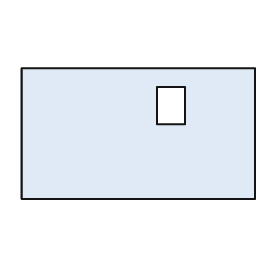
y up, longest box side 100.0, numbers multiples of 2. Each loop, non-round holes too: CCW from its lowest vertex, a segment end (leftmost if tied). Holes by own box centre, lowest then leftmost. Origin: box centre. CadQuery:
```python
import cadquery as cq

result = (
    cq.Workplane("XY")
    .moveTo(-50.0, -28.0)
    .lineTo(50.0, -28.0)
    .lineTo(50.0, 28.0)
    .lineTo(-50.0, 28.0)
    .close()
    .moveTo(8.0, 4.0)
    .lineTo(20.0, 4.0)
    .lineTo(20.0, 20.0)
    .lineTo(8.0, 20.0)
    .close()
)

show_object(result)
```